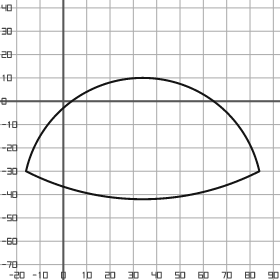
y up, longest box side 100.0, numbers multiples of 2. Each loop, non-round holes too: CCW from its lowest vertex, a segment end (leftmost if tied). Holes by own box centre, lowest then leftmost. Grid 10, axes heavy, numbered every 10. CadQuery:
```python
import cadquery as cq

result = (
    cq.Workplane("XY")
    .moveTo(-16.0, -30.0)
    .threePointArc((34.0, -42.0), (84.0, -30.0))
    .threePointArc((34.0, 10.0), (-16.0, -30.0))
    .close()
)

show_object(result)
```